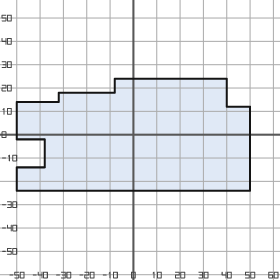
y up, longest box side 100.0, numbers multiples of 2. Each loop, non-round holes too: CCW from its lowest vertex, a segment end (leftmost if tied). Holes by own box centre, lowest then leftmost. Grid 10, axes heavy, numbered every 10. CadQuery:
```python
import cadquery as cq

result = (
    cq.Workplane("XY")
    .moveTo(-50.0, -24.0)
    .lineTo(50.0, -24.0)
    .lineTo(50.0, 12.0)
    .lineTo(40.0, 12.0)
    .lineTo(40.0, 24.0)
    .lineTo(-8.0, 24.0)
    .lineTo(-8.0, 18.0)
    .lineTo(-32.0, 18.0)
    .lineTo(-32.0, 14.0)
    .lineTo(-50.0, 14.0)
    .lineTo(-50.0, -2.0)
    .lineTo(-38.0, -2.0)
    .lineTo(-38.0, -14.0)
    .lineTo(-50.0, -14.0)
    .close()
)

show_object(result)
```